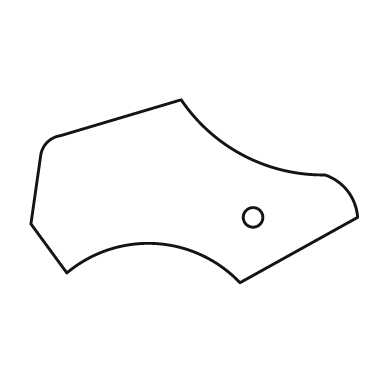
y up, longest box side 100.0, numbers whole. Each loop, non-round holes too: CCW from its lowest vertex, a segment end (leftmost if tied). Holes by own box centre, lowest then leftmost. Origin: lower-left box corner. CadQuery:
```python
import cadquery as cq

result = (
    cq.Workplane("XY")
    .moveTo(64.0, 0.0)
    .lineTo(100.0, 20.0)
    .threePointArc((97.0, 28.0), (90.0, 33.0))
    .threePointArc((65.0, 39.0), (46.0, 56.0))
    .lineTo(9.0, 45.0)
    .threePointArc((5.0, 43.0), (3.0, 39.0))
    .lineTo(0.0, 18.0)
    .lineTo(11.0, 3.0)
    .threePointArc((38.0, 12.0), (64.0, 0.0))
    .close()
    .moveTo(68.0, 20.0)
    .circle(3.0)
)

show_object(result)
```